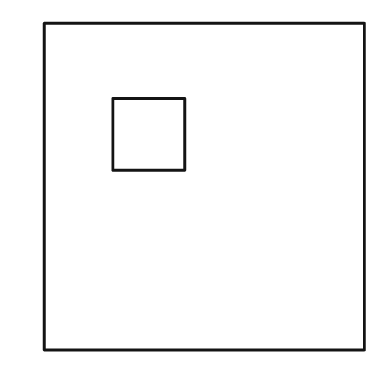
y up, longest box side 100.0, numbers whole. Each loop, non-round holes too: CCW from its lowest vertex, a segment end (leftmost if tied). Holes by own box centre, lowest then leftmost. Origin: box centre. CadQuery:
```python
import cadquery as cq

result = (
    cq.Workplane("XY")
    .moveTo(-49.0, -50.0)
    .lineTo(49.0, -50.0)
    .lineTo(49.0, 50.0)
    .lineTo(-49.0, 50.0)
    .close()
    .moveTo(-28.0, 5.0)
    .lineTo(-6.0, 5.0)
    .lineTo(-6.0, 27.0)
    .lineTo(-28.0, 27.0)
    .close()
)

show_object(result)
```